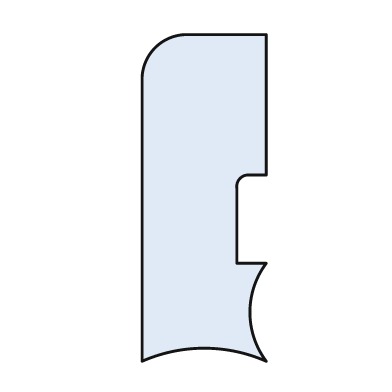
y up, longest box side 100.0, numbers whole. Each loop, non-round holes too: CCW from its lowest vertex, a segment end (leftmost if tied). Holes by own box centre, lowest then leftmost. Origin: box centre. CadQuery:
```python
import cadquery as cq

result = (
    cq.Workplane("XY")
    .moveTo(-19.0, -50.0)
    .threePointArc((0.0, -46.0), (19.0, -50.0))
    .threePointArc((14.0, -35.0), (19.0, -20.0))
    .lineTo(10.0, -20.0)
    .lineTo(10.0, 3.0)
    .threePointArc((11.0, 6.0), (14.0, 7.0))
    .lineTo(19.0, 7.0)
    .lineTo(19.0, 50.0)
    .lineTo(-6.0, 50.0)
    .threePointArc((-15.0, 46.0), (-19.0, 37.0))
    .close()
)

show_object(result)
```